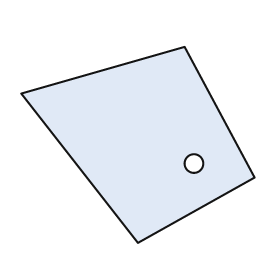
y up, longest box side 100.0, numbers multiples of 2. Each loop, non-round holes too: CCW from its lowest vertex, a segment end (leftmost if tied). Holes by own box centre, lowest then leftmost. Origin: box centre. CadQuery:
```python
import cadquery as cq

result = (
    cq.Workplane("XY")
    .moveTo(0.0, -42.0)
    .lineTo(50.0, -14.0)
    .lineTo(20.0, 42.0)
    .lineTo(-50.0, 22.0)
    .close()
    .moveTo(24.0, -8.0)
    .circle(4.0)
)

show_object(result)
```